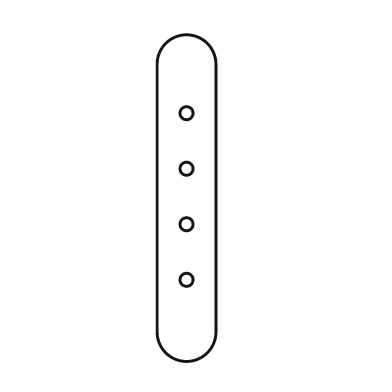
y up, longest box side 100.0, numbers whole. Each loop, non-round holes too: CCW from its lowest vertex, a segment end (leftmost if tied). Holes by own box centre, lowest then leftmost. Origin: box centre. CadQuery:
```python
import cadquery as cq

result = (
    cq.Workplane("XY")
    .moveTo(-9.0, -41.0)
    .threePointArc((0.0, -50.0), (9.0, -41.0))
    .lineTo(9.0, 41.0)
    .threePointArc((0.0, 50.0), (-9.0, 41.0))
    .close()
    .moveTo(0.0, -25.0)
    .circle(2.0)
    .moveTo(0.0, -8.0)
    .circle(2.0)
    .moveTo(0.0, 9.0)
    .circle(2.0)
    .moveTo(0.0, 26.0)
    .circle(2.0)
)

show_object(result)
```